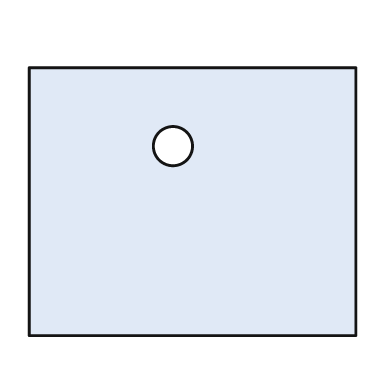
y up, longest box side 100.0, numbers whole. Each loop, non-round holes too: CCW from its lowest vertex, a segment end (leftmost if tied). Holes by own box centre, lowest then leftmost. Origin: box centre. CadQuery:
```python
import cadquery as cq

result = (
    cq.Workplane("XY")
    .moveTo(-50.0, -41.0)
    .lineTo(50.0, -41.0)
    .lineTo(50.0, 41.0)
    .lineTo(-50.0, 41.0)
    .close()
    .moveTo(-6.0, 17.0)
    .circle(6.0)
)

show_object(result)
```